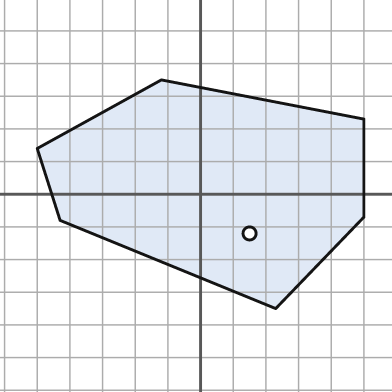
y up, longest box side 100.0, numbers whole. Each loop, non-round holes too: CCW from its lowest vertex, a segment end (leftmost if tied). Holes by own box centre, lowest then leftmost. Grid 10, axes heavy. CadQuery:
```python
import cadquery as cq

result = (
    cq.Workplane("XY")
    .moveTo(23.0, -35.0)
    .lineTo(50.0, -7.0)
    .lineTo(50.0, 23.0)
    .lineTo(-12.0, 35.0)
    .lineTo(-50.0, 14.0)
    .lineTo(-43.0, -8.0)
    .close()
    .moveTo(15.0, -12.0)
    .circle(2.0)
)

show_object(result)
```